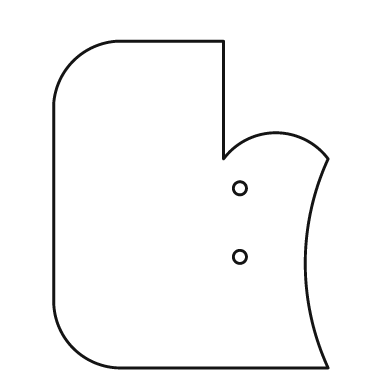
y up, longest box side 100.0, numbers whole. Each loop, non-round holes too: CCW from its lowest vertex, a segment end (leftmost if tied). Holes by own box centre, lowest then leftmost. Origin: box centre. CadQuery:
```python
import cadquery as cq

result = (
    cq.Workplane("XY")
    .moveTo(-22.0, -50.0)
    .lineTo(42.0, -50.0)
    .threePointArc((35.0, -18.0), (42.0, 14.0))
    .threePointArc((26.0, 22.0), (10.0, 14.0))
    .lineTo(10.0, 50.0)
    .lineTo(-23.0, 50.0)
    .threePointArc((-36.0, 44.0), (-42.0, 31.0))
    .lineTo(-42.0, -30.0)
    .threePointArc((-36.0, -44.0), (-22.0, -50.0))
    .close()
    .moveTo(15.0, -16.0)
    .circle(2.0)
    .moveTo(15.0, 5.0)
    .circle(2.0)
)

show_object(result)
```